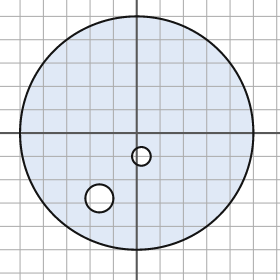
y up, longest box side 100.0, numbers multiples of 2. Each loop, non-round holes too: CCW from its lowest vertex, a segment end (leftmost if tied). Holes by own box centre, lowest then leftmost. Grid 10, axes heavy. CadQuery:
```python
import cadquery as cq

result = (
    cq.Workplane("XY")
    .moveTo(0.0, 0.0)
    .circle(50.0)
    .moveTo(-16.0, -28.0)
    .circle(6.0)
    .moveTo(2.0, -10.0)
    .circle(4.0)
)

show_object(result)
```